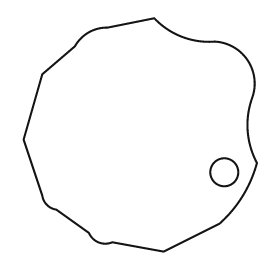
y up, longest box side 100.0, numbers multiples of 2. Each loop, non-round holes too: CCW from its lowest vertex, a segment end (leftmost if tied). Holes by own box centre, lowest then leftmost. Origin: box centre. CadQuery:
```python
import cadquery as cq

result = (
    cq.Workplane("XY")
    .moveTo(10.0, -50.0)
    .lineTo(34.0, -38.0)
    .threePointArc((44.0, -26.0), (50.0, -12.0))
    .threePointArc((46.0, 2.0), (48.0, 16.0))
    .threePointArc((46.0, 32.0), (32.0, 40.0))
    .threePointArc((18.0, 42.0), (6.0, 50.0))
    .lineTo(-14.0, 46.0)
    .threePointArc((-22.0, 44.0), (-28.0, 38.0))
    .lineTo(-42.0, 26.0)
    .lineTo(-50.0, -2.0)
    .lineTo(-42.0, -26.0)
    .threePointArc((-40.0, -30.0), (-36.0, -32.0))
    .lineTo(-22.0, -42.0)
    .threePointArc((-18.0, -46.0), (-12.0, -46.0))
    .close()
    .moveTo(36.0, -16.0)
    .circle(6.0)
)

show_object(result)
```